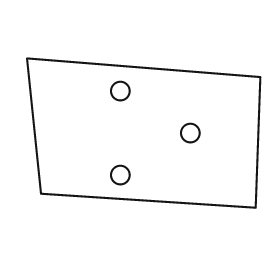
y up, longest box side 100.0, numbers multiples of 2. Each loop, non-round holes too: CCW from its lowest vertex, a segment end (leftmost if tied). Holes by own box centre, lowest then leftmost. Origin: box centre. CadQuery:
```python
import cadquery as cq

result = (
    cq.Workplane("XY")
    .moveTo(48.0, -32.0)
    .lineTo(50.0, 24.0)
    .lineTo(-50.0, 32.0)
    .lineTo(-44.0, -26.0)
    .close()
    .moveTo(-10.0, -18.0)
    .circle(4.0)
    .moveTo(20.0, 0.0)
    .circle(4.0)
    .moveTo(-10.0, 18.0)
    .circle(4.0)
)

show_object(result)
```